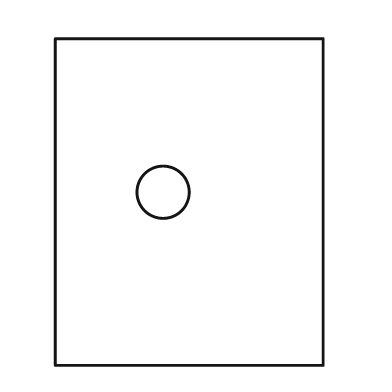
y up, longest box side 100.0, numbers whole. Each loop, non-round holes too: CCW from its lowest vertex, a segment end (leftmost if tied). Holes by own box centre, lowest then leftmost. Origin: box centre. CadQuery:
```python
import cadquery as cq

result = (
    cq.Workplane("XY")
    .moveTo(-41.0, -50.0)
    .lineTo(41.0, -50.0)
    .lineTo(41.0, 50.0)
    .lineTo(-41.0, 50.0)
    .close()
    .moveTo(-8.0, 3.0)
    .circle(8.0)
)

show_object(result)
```